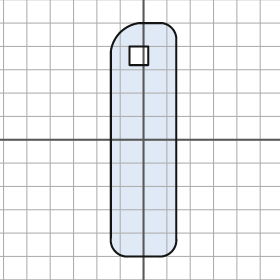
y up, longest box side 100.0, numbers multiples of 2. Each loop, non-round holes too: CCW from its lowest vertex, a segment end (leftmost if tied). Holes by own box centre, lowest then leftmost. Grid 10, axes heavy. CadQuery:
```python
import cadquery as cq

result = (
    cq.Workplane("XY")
    .moveTo(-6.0, -50.0)
    .lineTo(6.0, -50.0)
    .threePointArc((12.0, -48.0), (14.0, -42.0))
    .lineTo(14.0, 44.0)
    .threePointArc((12.0, 48.0), (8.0, 50.0))
    .lineTo(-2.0, 50.0)
    .threePointArc((-10.0, 46.0), (-14.0, 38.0))
    .lineTo(-14.0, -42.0)
    .threePointArc((-12.0, -48.0), (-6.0, -50.0))
    .close()
    .moveTo(-6.0, 32.0)
    .lineTo(2.0, 32.0)
    .lineTo(2.0, 40.0)
    .lineTo(-6.0, 40.0)
    .close()
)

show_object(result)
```